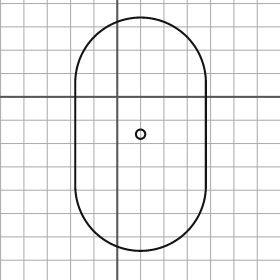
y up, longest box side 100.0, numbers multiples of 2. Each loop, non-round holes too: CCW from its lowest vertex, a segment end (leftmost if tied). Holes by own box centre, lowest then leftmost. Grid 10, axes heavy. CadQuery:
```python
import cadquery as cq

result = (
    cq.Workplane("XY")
    .moveTo(-18.0, -38.0)
    .threePointArc((10.0, -66.0), (38.0, -38.0))
    .lineTo(38.0, 6.0)
    .threePointArc((10.0, 34.0), (-18.0, 6.0))
    .close()
    .moveTo(10.0, -16.0)
    .circle(2.0)
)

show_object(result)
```